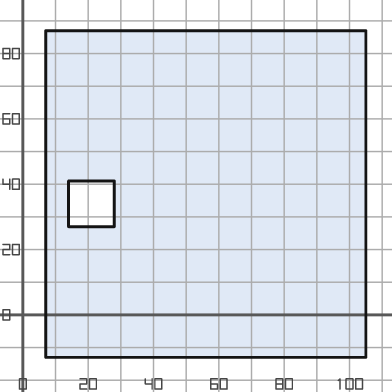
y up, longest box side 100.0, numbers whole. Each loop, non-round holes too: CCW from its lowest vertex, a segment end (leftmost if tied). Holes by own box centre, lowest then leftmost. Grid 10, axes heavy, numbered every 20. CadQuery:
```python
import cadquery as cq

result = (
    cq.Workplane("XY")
    .moveTo(7.0, -13.0)
    .lineTo(105.0, -13.0)
    .lineTo(105.0, 87.0)
    .lineTo(7.0, 87.0)
    .close()
    .moveTo(14.0, 27.0)
    .lineTo(28.0, 27.0)
    .lineTo(28.0, 41.0)
    .lineTo(14.0, 41.0)
    .close()
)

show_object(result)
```